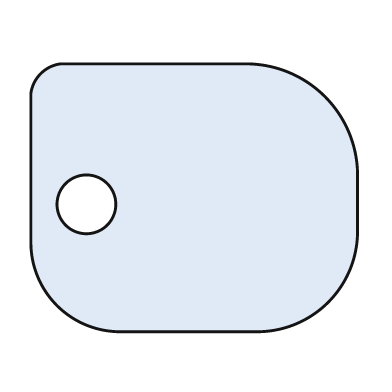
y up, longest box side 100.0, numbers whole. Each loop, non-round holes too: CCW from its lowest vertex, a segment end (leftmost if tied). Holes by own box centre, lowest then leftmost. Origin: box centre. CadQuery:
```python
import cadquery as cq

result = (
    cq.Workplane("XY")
    .moveTo(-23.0, -41.0)
    .lineTo(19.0, -41.0)
    .threePointArc((41.0, -32.0), (50.0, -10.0))
    .lineTo(50.0, 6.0)
    .threePointArc((40.0, 31.0), (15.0, 41.0))
    .lineTo(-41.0, 41.0)
    .threePointArc((-47.0, 38.0), (-50.0, 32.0))
    .lineTo(-50.0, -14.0)
    .threePointArc((-42.0, -33.0), (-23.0, -41.0))
    .close()
    .moveTo(-33.0, -2.0)
    .circle(9.0)
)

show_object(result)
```